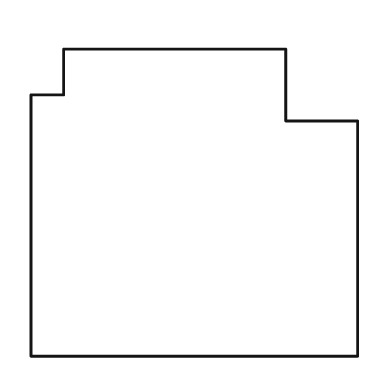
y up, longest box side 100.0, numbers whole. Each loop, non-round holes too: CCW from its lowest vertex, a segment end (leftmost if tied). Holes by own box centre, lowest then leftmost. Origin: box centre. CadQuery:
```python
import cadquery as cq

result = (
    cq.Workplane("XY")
    .moveTo(-50.0, -47.0)
    .lineTo(50.0, -47.0)
    .lineTo(50.0, 25.0)
    .lineTo(28.0, 25.0)
    .lineTo(28.0, 47.0)
    .lineTo(-40.0, 47.0)
    .lineTo(-40.0, 33.0)
    .lineTo(-50.0, 33.0)
    .close()
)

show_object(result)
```